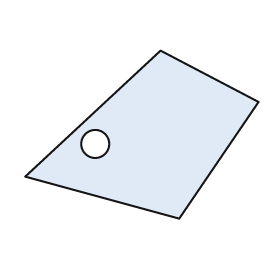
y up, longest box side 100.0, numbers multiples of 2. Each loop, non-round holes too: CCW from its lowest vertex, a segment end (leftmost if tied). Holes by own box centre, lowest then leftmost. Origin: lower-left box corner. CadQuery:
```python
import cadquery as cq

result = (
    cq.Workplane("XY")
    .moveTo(66.0, 0.0)
    .lineTo(100.0, 50.0)
    .lineTo(58.0, 72.0)
    .lineTo(0.0, 18.0)
    .close()
    .moveTo(30.0, 32.0)
    .circle(6.0)
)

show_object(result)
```